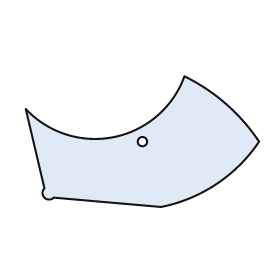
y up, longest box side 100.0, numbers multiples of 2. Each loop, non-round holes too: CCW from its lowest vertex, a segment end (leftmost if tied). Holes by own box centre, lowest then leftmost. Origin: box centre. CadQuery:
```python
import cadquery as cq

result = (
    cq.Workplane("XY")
    .moveTo(8.0, -28.0)
    .threePointArc((32.0, -18.0), (50.0, 0.0))
    .threePointArc((36.0, 16.0), (18.0, 28.0))
    .threePointArc((-12.0, 2.0), (-50.0, 14.0))
    .lineTo(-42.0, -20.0)
    .threePointArc((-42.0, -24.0), (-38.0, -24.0))
    .close()
    .moveTo(0.0, 0.0)
    .circle(2.0)
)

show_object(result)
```